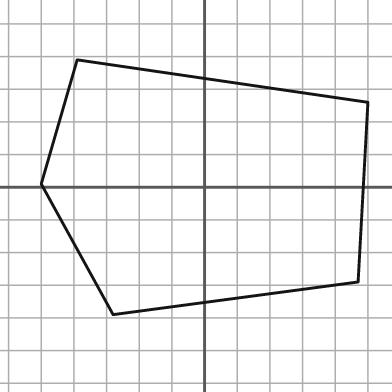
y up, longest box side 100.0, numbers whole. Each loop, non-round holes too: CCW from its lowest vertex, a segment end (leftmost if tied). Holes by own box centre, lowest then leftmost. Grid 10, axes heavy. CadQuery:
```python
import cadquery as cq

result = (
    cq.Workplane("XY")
    .moveTo(-28.0, -39.0)
    .lineTo(47.0, -29.0)
    .lineTo(50.0, 26.0)
    .lineTo(-39.0, 39.0)
    .lineTo(-50.0, 1.0)
    .close()
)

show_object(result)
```